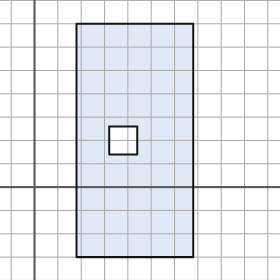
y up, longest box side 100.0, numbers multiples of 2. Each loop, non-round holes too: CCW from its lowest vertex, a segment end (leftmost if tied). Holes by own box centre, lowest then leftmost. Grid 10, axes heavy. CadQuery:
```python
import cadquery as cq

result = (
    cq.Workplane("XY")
    .moveTo(18.0, -30.0)
    .lineTo(68.0, -30.0)
    .lineTo(68.0, 70.0)
    .lineTo(18.0, 70.0)
    .close()
    .moveTo(32.0, 14.0)
    .lineTo(44.0, 14.0)
    .lineTo(44.0, 26.0)
    .lineTo(32.0, 26.0)
    .close()
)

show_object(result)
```